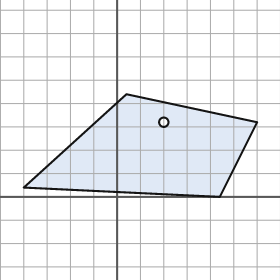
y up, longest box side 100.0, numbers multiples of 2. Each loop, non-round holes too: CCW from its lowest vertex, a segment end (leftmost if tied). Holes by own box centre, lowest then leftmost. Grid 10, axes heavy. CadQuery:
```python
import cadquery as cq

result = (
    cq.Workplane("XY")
    .moveTo(44.0, 0.0)
    .lineTo(60.0, 32.0)
    .lineTo(4.0, 44.0)
    .lineTo(-40.0, 4.0)
    .close()
    .moveTo(20.0, 32.0)
    .circle(2.0)
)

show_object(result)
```